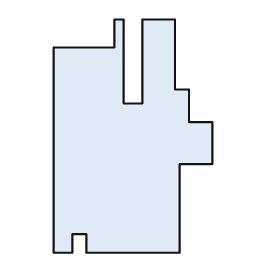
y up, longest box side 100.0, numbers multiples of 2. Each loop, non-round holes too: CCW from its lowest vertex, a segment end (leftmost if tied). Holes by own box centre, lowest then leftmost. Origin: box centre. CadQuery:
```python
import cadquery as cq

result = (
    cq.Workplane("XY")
    .moveTo(-34.0, -50.0)
    .lineTo(-26.0, -50.0)
    .lineTo(-26.0, -42.0)
    .lineTo(-20.0, -42.0)
    .lineTo(-20.0, -50.0)
    .lineTo(20.0, -50.0)
    .lineTo(20.0, -12.0)
    .lineTo(34.0, -12.0)
    .lineTo(34.0, 6.0)
    .lineTo(24.0, 6.0)
    .lineTo(24.0, 20.0)
    .lineTo(18.0, 20.0)
    .lineTo(18.0, 50.0)
    .lineTo(4.0, 50.0)
    .lineTo(4.0, 14.0)
    .lineTo(-4.0, 14.0)
    .lineTo(-4.0, 50.0)
    .lineTo(-8.0, 50.0)
    .lineTo(-8.0, 38.0)
    .lineTo(-34.0, 38.0)
    .close()
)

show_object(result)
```